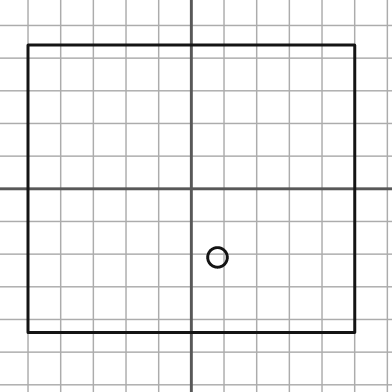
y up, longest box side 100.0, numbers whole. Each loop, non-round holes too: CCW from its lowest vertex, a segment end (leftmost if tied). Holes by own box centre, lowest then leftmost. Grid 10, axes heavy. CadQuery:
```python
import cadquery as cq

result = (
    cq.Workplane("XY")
    .moveTo(-50.0, -44.0)
    .lineTo(50.0, -44.0)
    .lineTo(50.0, 44.0)
    .lineTo(-50.0, 44.0)
    .close()
    .moveTo(8.0, -21.0)
    .circle(3.0)
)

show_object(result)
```